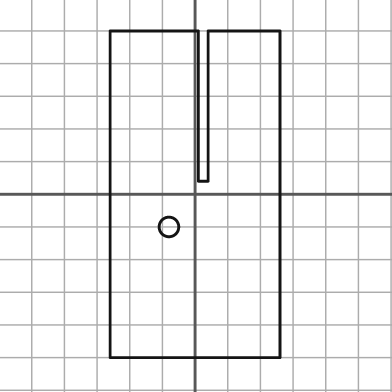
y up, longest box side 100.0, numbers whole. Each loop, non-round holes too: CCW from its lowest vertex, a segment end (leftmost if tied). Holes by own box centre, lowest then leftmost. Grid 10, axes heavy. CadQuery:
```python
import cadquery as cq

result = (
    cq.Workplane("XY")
    .moveTo(-26.0, -50.0)
    .lineTo(26.0, -50.0)
    .lineTo(26.0, 50.0)
    .lineTo(4.0, 50.0)
    .lineTo(4.0, 4.0)
    .lineTo(1.0, 4.0)
    .lineTo(1.0, 50.0)
    .lineTo(-26.0, 50.0)
    .close()
    .moveTo(-8.0, -10.0)
    .circle(3.0)
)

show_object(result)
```